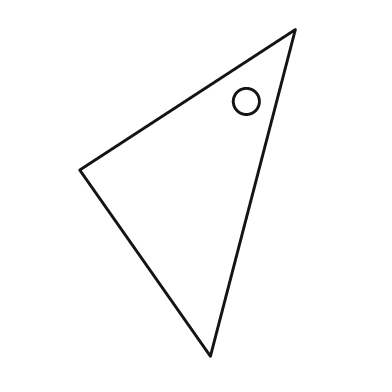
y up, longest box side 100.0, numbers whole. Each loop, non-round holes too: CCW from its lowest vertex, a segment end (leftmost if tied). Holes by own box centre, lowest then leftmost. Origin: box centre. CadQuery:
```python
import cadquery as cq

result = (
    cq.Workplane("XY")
    .moveTo(7.0, -50.0)
    .lineTo(33.0, 50.0)
    .lineTo(-33.0, 7.0)
    .close()
    .moveTo(18.0, 28.0)
    .circle(4.0)
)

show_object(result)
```